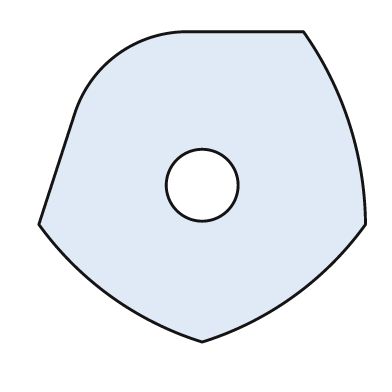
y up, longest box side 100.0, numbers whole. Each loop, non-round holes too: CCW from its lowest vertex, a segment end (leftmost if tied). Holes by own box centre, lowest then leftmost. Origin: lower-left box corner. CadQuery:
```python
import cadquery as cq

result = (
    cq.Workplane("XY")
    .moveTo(50.0, 0.0)
    .threePointArc((78.0, 14.0), (100.0, 36.0))
    .threePointArc((95.0, 67.0), (81.0, 95.0))
    .lineTo(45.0, 95.0)
    .threePointArc((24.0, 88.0), (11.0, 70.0))
    .lineTo(0.0, 36.0)
    .threePointArc((22.0, 14.0), (50.0, 0.0))
    .close()
    .moveTo(50.0, 48.0)
    .circle(11.0)
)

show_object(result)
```